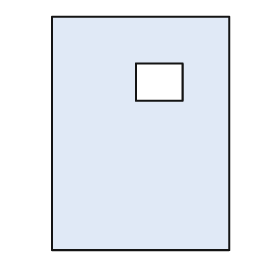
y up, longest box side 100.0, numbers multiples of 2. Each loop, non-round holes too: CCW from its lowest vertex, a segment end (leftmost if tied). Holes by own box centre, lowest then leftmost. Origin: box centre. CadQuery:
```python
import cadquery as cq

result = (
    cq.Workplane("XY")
    .moveTo(-38.0, -50.0)
    .lineTo(38.0, -50.0)
    .lineTo(38.0, 50.0)
    .lineTo(-38.0, 50.0)
    .close()
    .moveTo(-2.0, 14.0)
    .lineTo(18.0, 14.0)
    .lineTo(18.0, 30.0)
    .lineTo(-2.0, 30.0)
    .close()
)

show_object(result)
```